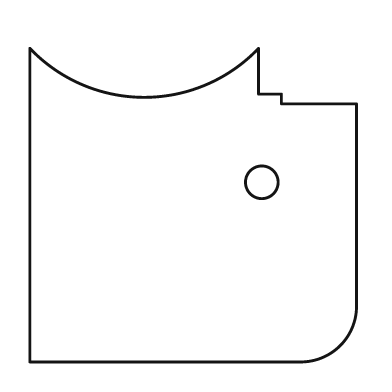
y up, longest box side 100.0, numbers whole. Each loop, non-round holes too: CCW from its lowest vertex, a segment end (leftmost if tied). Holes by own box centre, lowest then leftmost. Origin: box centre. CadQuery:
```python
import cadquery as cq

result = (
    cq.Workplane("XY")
    .moveTo(-50.0, -48.0)
    .lineTo(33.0, -48.0)
    .threePointArc((45.0, -43.0), (50.0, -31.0))
    .lineTo(50.0, 31.0)
    .lineTo(27.0, 31.0)
    .lineTo(27.0, 34.0)
    .lineTo(20.0, 34.0)
    .lineTo(20.0, 48.0)
    .threePointArc((-15.0, 33.0), (-50.0, 48.0))
    .close()
    .moveTo(21.0, 7.0)
    .circle(5.0)
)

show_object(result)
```